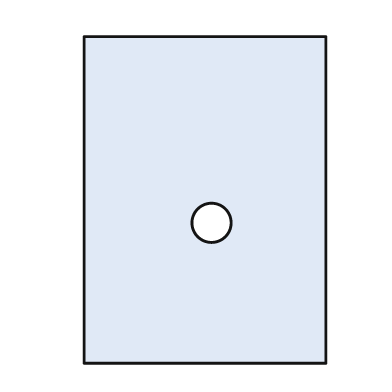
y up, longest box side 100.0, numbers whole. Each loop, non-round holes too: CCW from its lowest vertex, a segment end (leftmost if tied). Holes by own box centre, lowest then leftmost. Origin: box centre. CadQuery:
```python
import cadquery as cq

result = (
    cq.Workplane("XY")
    .moveTo(-37.0, -50.0)
    .lineTo(37.0, -50.0)
    .lineTo(37.0, 50.0)
    .lineTo(-37.0, 50.0)
    .close()
    .moveTo(2.0, -7.0)
    .circle(6.0)
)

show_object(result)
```